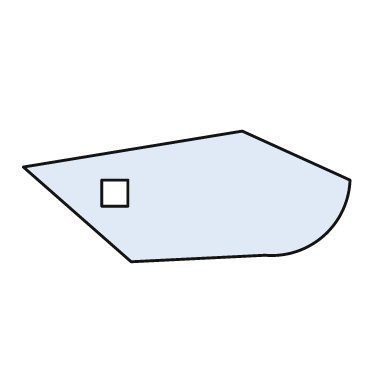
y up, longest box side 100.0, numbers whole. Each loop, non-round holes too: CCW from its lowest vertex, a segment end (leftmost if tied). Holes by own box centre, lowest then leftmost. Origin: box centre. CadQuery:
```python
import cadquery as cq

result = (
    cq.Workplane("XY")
    .moveTo(-17.0, -20.0)
    .lineTo(24.0, -18.0)
    .threePointArc((42.0, -12.0), (50.0, 5.0))
    .lineTo(17.0, 20.0)
    .lineTo(-50.0, 9.0)
    .close()
    .moveTo(-26.0, -3.0)
    .lineTo(-18.0, -3.0)
    .lineTo(-18.0, 5.0)
    .lineTo(-26.0, 5.0)
    .close()
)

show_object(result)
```